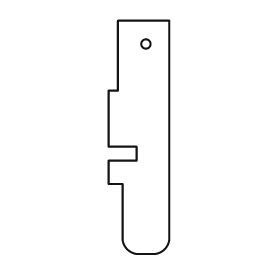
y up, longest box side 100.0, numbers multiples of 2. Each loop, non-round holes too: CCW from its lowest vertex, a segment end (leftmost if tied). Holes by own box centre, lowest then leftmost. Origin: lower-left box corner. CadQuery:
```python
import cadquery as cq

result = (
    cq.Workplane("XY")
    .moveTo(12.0, 0.0)
    .lineTo(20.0, 0.0)
    .threePointArc((24.0, 2.0), (26.0, 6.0))
    .lineTo(26.0, 100.0)
    .lineTo(4.0, 100.0)
    .lineTo(4.0, 70.0)
    .lineTo(0.0, 70.0)
    .lineTo(0.0, 46.0)
    .lineTo(12.0, 46.0)
    .lineTo(12.0, 40.0)
    .lineTo(0.0, 40.0)
    .lineTo(0.0, 30.0)
    .lineTo(6.0, 30.0)
    .lineTo(6.0, 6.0)
    .threePointArc((8.0, 2.0), (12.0, 0.0))
    .close()
    .moveTo(16.0, 90.0)
    .circle(2.0)
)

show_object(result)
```